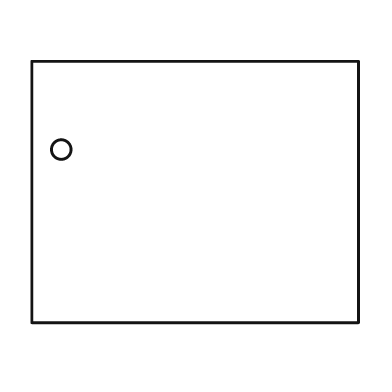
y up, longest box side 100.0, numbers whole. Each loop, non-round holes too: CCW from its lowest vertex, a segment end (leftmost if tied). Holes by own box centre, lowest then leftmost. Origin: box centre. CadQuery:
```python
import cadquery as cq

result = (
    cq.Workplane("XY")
    .moveTo(-50.0, -40.0)
    .lineTo(50.0, -40.0)
    .lineTo(50.0, 40.0)
    .lineTo(-50.0, 40.0)
    .close()
    .moveTo(-41.0, 13.0)
    .circle(3.0)
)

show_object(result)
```